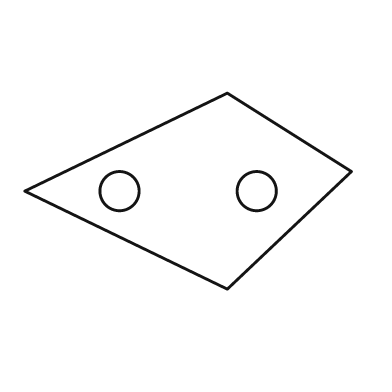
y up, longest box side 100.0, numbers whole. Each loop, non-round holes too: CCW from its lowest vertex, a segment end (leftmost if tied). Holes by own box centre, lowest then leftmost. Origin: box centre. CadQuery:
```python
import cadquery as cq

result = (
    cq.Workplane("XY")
    .moveTo(12.0, -30.0)
    .lineTo(50.0, 6.0)
    .lineTo(12.0, 30.0)
    .lineTo(-50.0, 0.0)
    .close()
    .moveTo(-21.0, 0.0)
    .circle(6.0)
    .moveTo(21.0, 0.0)
    .circle(6.0)
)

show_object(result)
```